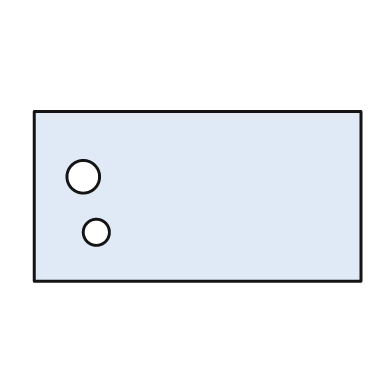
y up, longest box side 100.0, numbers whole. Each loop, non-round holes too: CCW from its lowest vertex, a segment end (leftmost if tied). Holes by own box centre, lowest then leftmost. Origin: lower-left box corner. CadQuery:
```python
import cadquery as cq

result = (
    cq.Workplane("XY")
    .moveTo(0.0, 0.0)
    .lineTo(100.0, 0.0)
    .lineTo(100.0, 52.0)
    .lineTo(0.0, 52.0)
    .close()
    .moveTo(19.0, 15.0)
    .circle(4.0)
    .moveTo(15.0, 32.0)
    .circle(5.0)
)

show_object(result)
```